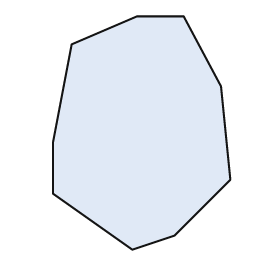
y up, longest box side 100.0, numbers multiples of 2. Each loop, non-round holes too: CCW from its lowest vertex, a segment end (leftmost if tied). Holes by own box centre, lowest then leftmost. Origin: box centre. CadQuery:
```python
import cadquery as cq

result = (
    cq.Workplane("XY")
    .moveTo(-4.0, -50.0)
    .lineTo(14.0, -44.0)
    .lineTo(38.0, -20.0)
    .lineTo(34.0, 20.0)
    .lineTo(18.0, 50.0)
    .lineTo(-2.0, 50.0)
    .lineTo(-30.0, 38.0)
    .lineTo(-38.0, -4.0)
    .lineTo(-38.0, -26.0)
    .close()
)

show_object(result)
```